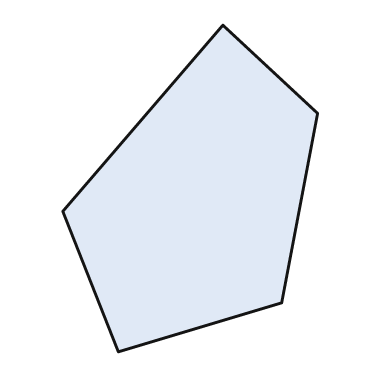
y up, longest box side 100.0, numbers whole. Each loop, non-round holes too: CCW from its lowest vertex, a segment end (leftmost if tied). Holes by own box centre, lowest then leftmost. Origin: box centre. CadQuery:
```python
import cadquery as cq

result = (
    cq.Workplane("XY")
    .moveTo(-22.0, -50.0)
    .lineTo(28.0, -35.0)
    .lineTo(39.0, 23.0)
    .lineTo(10.0, 50.0)
    .lineTo(-39.0, -7.0)
    .close()
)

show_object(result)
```